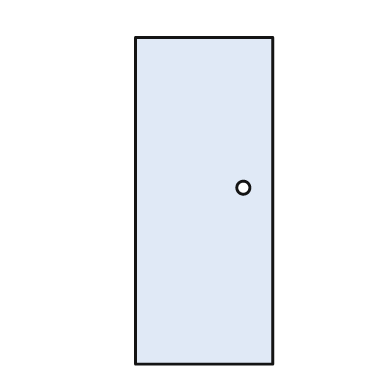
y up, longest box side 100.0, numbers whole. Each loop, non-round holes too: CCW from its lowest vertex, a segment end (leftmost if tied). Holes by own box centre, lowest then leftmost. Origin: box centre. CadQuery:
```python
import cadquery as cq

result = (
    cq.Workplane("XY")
    .moveTo(-21.0, -50.0)
    .lineTo(21.0, -50.0)
    .lineTo(21.0, 50.0)
    .lineTo(-21.0, 50.0)
    .close()
    .moveTo(12.0, 4.0)
    .circle(2.0)
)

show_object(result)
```